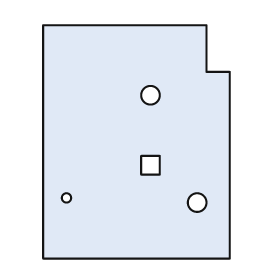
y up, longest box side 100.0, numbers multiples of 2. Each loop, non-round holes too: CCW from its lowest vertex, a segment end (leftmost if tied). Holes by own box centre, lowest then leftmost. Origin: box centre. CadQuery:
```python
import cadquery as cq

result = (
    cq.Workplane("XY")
    .moveTo(-40.0, -50.0)
    .lineTo(40.0, -50.0)
    .lineTo(40.0, 30.0)
    .lineTo(30.0, 30.0)
    .lineTo(30.0, 50.0)
    .lineTo(-40.0, 50.0)
    .close()
    .moveTo(26.0, -26.0)
    .circle(4.0)
    .moveTo(-30.0, -24.0)
    .circle(2.0)
    .moveTo(2.0, -14.0)
    .lineTo(10.0, -14.0)
    .lineTo(10.0, -6.0)
    .lineTo(2.0, -6.0)
    .close()
    .moveTo(6.0, 20.0)
    .circle(4.0)
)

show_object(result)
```